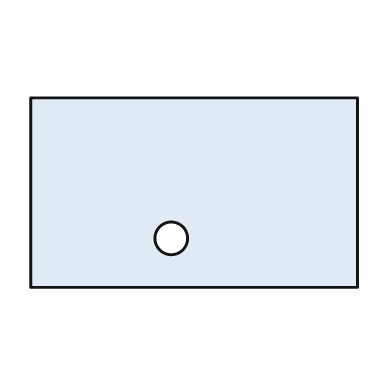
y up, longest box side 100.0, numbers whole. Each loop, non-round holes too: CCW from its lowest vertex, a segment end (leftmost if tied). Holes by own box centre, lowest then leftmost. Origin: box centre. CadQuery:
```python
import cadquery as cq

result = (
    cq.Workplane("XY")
    .moveTo(-50.0, -29.0)
    .lineTo(50.0, -29.0)
    .lineTo(50.0, 29.0)
    .lineTo(-50.0, 29.0)
    .close()
    .moveTo(-7.0, -14.0)
    .circle(5.0)
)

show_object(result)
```